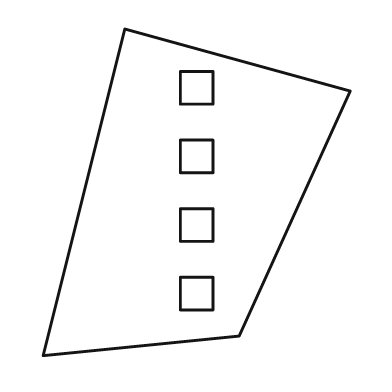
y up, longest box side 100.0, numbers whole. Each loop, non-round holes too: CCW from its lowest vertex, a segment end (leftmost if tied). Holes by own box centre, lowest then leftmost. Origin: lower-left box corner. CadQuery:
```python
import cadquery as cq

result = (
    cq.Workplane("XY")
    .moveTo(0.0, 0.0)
    .lineTo(60.0, 6.0)
    .lineTo(94.0, 81.0)
    .lineTo(25.0, 100.0)
    .close()
    .moveTo(42.0, 14.0)
    .lineTo(52.0, 14.0)
    .lineTo(52.0, 24.0)
    .lineTo(42.0, 24.0)
    .close()
    .moveTo(42.0, 35.0)
    .lineTo(52.0, 35.0)
    .lineTo(52.0, 45.0)
    .lineTo(42.0, 45.0)
    .close()
    .moveTo(42.0, 56.0)
    .lineTo(52.0, 56.0)
    .lineTo(52.0, 66.0)
    .lineTo(42.0, 66.0)
    .close()
    .moveTo(42.0, 77.0)
    .lineTo(52.0, 77.0)
    .lineTo(52.0, 87.0)
    .lineTo(42.0, 87.0)
    .close()
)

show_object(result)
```